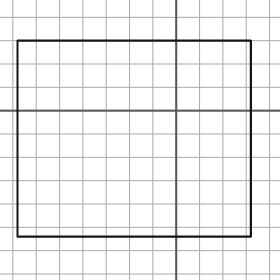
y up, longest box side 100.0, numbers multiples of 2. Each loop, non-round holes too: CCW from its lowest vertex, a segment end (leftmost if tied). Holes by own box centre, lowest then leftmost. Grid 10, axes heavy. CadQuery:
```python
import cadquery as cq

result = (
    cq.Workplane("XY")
    .moveTo(-68.0, -54.0)
    .lineTo(32.0, -54.0)
    .lineTo(32.0, 30.0)
    .lineTo(-68.0, 30.0)
    .close()
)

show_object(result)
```